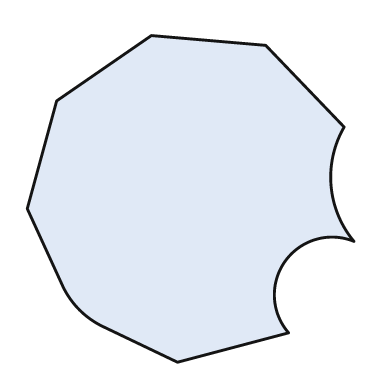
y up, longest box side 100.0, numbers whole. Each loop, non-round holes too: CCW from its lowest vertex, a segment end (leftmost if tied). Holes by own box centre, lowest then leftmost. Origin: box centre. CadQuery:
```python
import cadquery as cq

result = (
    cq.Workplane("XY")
    .moveTo(-4.0, -50.0)
    .lineTo(30.0, -41.0)
    .threePointArc((29.0, -19.0), (50.0, -13.0))
    .threePointArc((43.0, 4.0), (47.0, 22.0))
    .lineTo(23.0, 47.0)
    .lineTo(-12.0, 50.0)
    .lineTo(-41.0, 30.0)
    .lineTo(-50.0, -3.0)
    .lineTo(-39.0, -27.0)
    .threePointArc((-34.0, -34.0), (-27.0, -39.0))
    .close()
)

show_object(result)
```